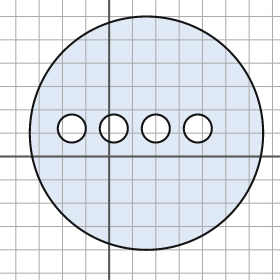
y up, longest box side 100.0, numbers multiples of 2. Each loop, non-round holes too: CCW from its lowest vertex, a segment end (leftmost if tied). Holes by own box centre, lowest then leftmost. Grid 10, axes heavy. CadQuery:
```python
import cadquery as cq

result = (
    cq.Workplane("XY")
    .moveTo(16.0, 10.0)
    .circle(50.0)
    .moveTo(-16.0, 12.0)
    .circle(6.0)
    .moveTo(2.0, 12.0)
    .circle(6.0)
    .moveTo(20.0, 12.0)
    .circle(6.0)
    .moveTo(38.0, 12.0)
    .circle(6.0)
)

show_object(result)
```